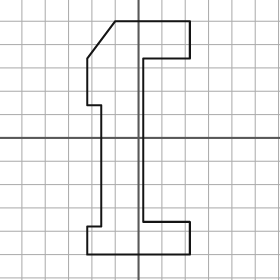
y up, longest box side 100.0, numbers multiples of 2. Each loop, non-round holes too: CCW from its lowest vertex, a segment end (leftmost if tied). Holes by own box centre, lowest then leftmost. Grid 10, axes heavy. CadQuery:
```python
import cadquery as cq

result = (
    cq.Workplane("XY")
    .moveTo(-22.0, -50.0)
    .lineTo(22.0, -50.0)
    .lineTo(22.0, -36.0)
    .lineTo(2.0, -36.0)
    .lineTo(2.0, 34.0)
    .lineTo(22.0, 34.0)
    .lineTo(22.0, 50.0)
    .lineTo(-10.0, 50.0)
    .lineTo(-22.0, 34.0)
    .lineTo(-22.0, 14.0)
    .lineTo(-16.0, 14.0)
    .lineTo(-16.0, -38.0)
    .lineTo(-22.0, -38.0)
    .close()
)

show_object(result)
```